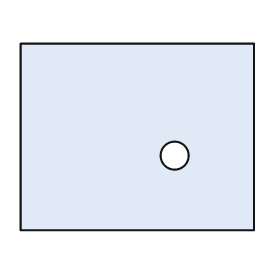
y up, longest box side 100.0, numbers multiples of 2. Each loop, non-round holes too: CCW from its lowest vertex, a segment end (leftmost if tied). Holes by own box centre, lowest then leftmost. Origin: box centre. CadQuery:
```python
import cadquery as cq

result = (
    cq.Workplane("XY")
    .moveTo(-50.0, -40.0)
    .lineTo(50.0, -40.0)
    .lineTo(50.0, 40.0)
    .lineTo(-50.0, 40.0)
    .close()
    .moveTo(16.0, -8.0)
    .circle(6.0)
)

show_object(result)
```